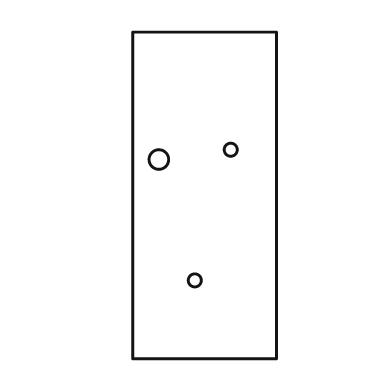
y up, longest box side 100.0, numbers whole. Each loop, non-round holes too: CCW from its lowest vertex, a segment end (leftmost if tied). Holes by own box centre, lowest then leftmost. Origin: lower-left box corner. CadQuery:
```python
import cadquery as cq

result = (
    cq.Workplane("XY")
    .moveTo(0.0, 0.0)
    .lineTo(44.0, 0.0)
    .lineTo(44.0, 100.0)
    .lineTo(0.0, 100.0)
    .close()
    .moveTo(19.0, 24.0)
    .circle(2.0)
    .moveTo(8.0, 61.0)
    .circle(3.0)
    .moveTo(30.0, 64.0)
    .circle(2.0)
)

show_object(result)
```